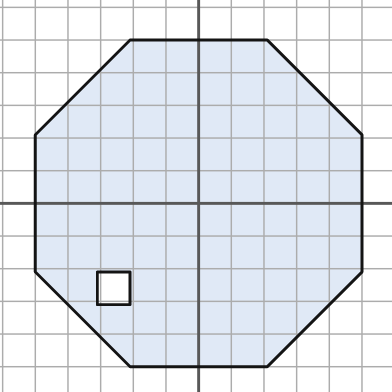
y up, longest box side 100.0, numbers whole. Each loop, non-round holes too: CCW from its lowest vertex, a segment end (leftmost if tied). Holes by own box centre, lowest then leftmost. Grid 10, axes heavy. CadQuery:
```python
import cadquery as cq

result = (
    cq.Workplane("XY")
    .moveTo(-21.0, -50.0)
    .lineTo(21.0, -50.0)
    .lineTo(50.0, -21.0)
    .lineTo(50.0, 21.0)
    .lineTo(21.0, 50.0)
    .lineTo(-21.0, 50.0)
    .lineTo(-50.0, 21.0)
    .lineTo(-50.0, -21.0)
    .close()
    .moveTo(-31.0, -31.0)
    .lineTo(-21.0, -31.0)
    .lineTo(-21.0, -21.0)
    .lineTo(-31.0, -21.0)
    .close()
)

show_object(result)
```